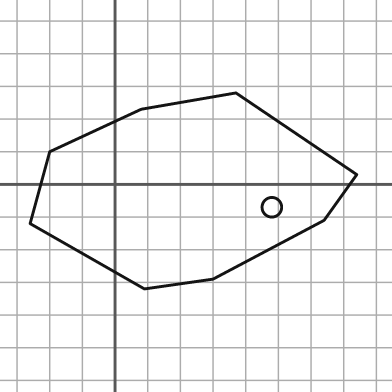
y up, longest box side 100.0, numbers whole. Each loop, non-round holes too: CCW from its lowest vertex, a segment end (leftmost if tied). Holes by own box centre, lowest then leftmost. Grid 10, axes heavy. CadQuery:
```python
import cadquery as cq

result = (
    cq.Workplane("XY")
    .moveTo(9.0, -32.0)
    .lineTo(30.0, -29.0)
    .lineTo(64.0, -11.0)
    .lineTo(74.0, 3.0)
    .lineTo(37.0, 28.0)
    .lineTo(8.0, 23.0)
    .lineTo(-20.0, 10.0)
    .lineTo(-26.0, -12.0)
    .close()
    .moveTo(48.0, -7.0)
    .circle(3.0)
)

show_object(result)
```